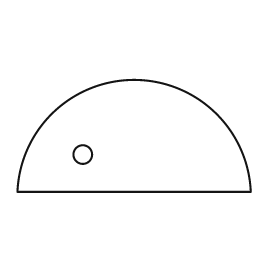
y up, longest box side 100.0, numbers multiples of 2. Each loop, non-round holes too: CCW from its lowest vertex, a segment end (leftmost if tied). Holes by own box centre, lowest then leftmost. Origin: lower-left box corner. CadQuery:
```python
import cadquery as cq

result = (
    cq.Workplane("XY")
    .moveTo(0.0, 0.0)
    .lineTo(100.0, 0.0)
    .threePointArc((50.0, 48.0), (0.0, 0.0))
    .close()
    .moveTo(28.0, 16.0)
    .circle(4.0)
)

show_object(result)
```